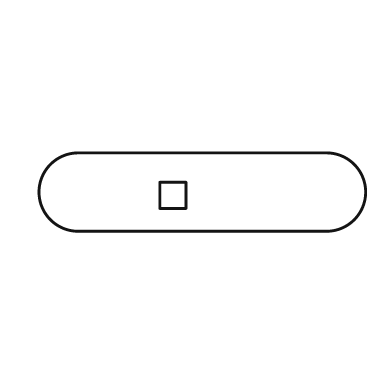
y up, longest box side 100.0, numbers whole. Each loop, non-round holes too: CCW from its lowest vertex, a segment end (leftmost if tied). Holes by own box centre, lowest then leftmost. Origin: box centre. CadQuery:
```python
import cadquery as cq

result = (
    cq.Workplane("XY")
    .moveTo(-38.0, -12.0)
    .lineTo(38.0, -12.0)
    .threePointArc((50.0, 0.0), (38.0, 12.0))
    .lineTo(-38.0, 12.0)
    .threePointArc((-50.0, 0.0), (-38.0, -12.0))
    .close()
    .moveTo(-13.0, -5.0)
    .lineTo(-5.0, -5.0)
    .lineTo(-5.0, 3.0)
    .lineTo(-13.0, 3.0)
    .close()
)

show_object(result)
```